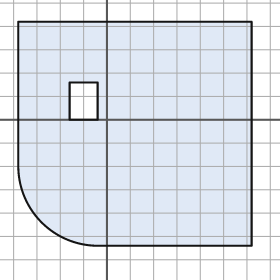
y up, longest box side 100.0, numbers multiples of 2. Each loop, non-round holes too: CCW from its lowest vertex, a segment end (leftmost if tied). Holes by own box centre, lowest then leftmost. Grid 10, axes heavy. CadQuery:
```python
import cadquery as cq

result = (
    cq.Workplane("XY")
    .moveTo(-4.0, -54.0)
    .lineTo(62.0, -54.0)
    .lineTo(62.0, 42.0)
    .lineTo(-38.0, 42.0)
    .lineTo(-38.0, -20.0)
    .threePointArc((-28.0, -44.0), (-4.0, -54.0))
    .close()
    .moveTo(-16.0, 0.0)
    .lineTo(-4.0, 0.0)
    .lineTo(-4.0, 16.0)
    .lineTo(-16.0, 16.0)
    .close()
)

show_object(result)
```